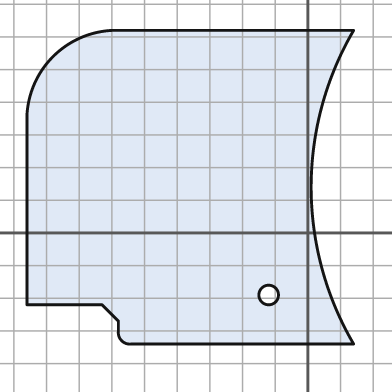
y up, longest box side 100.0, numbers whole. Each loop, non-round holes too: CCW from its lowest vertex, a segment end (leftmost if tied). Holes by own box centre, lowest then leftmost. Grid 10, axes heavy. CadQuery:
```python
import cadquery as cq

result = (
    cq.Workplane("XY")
    .moveTo(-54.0, -34.0)
    .lineTo(14.0, -34.0)
    .threePointArc((1.0, 14.0), (14.0, 62.0))
    .lineTo(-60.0, 62.0)
    .threePointArc((-78.0, 54.0), (-86.0, 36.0))
    .lineTo(-86.0, -22.0)
    .lineTo(-63.0, -22.0)
    .lineTo(-58.0, -27.0)
    .lineTo(-58.0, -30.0)
    .threePointArc((-57.0, -33.0), (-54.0, -34.0))
    .close()
    .moveTo(-12.0, -19.0)
    .circle(3.0)
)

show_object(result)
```